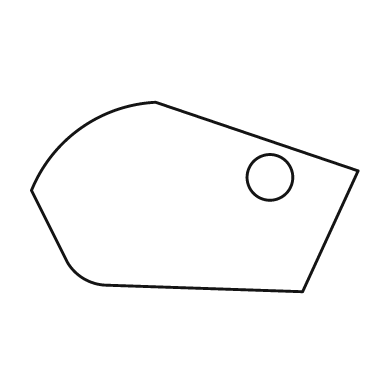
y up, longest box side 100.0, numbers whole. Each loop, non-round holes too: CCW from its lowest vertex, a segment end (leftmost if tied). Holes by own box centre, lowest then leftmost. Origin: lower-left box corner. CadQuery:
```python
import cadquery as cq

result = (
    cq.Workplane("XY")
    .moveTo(83.0, 0.0)
    .lineTo(100.0, 37.0)
    .lineTo(38.0, 58.0)
    .threePointArc((15.0, 50.0), (0.0, 31.0))
    .lineTo(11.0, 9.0)
    .threePointArc((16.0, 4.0), (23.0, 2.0))
    .close()
    .moveTo(73.0, 35.0)
    .circle(7.0)
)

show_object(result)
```